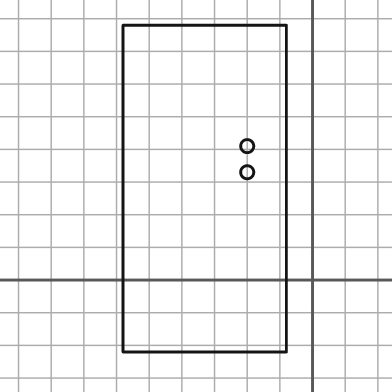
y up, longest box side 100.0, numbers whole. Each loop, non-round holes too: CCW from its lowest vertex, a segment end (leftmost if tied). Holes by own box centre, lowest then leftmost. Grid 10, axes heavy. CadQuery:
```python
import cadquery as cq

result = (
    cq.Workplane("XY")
    .moveTo(-58.0, -22.0)
    .lineTo(-8.0, -22.0)
    .lineTo(-8.0, 78.0)
    .lineTo(-58.0, 78.0)
    .close()
    .moveTo(-20.0, 33.0)
    .circle(2.0)
    .moveTo(-20.0, 41.0)
    .circle(2.0)
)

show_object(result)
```